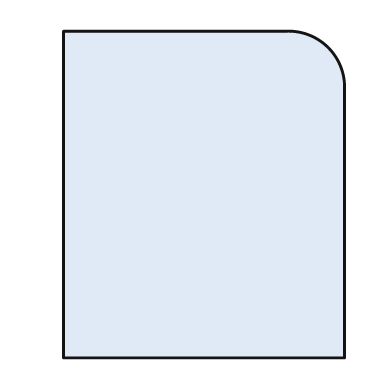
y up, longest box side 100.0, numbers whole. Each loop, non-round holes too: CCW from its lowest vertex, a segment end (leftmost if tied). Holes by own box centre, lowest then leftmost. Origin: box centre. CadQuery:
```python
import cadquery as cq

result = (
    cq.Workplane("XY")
    .moveTo(-43.0, -50.0)
    .lineTo(43.0, -50.0)
    .lineTo(43.0, 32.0)
    .threePointArc((38.0, 45.0), (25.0, 50.0))
    .lineTo(-43.0, 50.0)
    .close()
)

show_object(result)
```